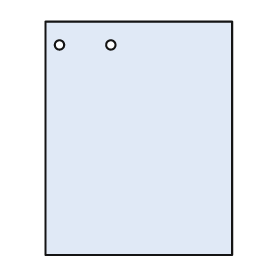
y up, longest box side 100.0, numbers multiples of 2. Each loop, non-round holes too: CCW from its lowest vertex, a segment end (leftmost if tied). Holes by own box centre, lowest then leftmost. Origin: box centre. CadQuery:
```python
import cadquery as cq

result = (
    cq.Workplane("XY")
    .moveTo(-40.0, -50.0)
    .lineTo(40.0, -50.0)
    .lineTo(40.0, 50.0)
    .lineTo(-40.0, 50.0)
    .close()
    .moveTo(-34.0, 40.0)
    .circle(2.0)
    .moveTo(-12.0, 40.0)
    .circle(2.0)
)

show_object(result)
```